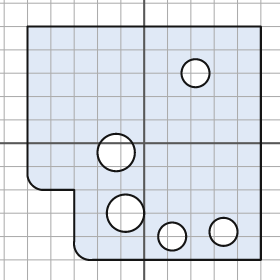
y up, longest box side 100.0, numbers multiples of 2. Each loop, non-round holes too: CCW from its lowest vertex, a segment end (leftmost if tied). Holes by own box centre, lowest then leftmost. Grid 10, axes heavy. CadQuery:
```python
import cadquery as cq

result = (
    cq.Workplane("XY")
    .moveTo(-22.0, -50.0)
    .lineTo(50.0, -50.0)
    .lineTo(50.0, 50.0)
    .lineTo(-50.0, 50.0)
    .lineTo(-50.0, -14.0)
    .threePointArc((-48.0, -18.0), (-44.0, -20.0))
    .lineTo(-30.0, -20.0)
    .lineTo(-30.0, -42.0)
    .threePointArc((-28.0, -48.0), (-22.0, -50.0))
    .close()
    .moveTo(12.0, -40.0)
    .circle(6.0)
    .moveTo(34.0, -38.0)
    .circle(6.0)
    .moveTo(-8.0, -30.0)
    .circle(8.0)
    .moveTo(-12.0, -4.0)
    .circle(8.0)
    .moveTo(22.0, 30.0)
    .circle(6.0)
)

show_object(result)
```